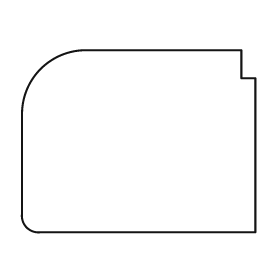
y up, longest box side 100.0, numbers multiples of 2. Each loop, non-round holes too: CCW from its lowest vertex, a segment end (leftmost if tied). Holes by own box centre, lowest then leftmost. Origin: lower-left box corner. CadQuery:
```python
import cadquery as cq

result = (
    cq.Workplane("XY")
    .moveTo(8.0, 0.0)
    .lineTo(100.0, 0.0)
    .lineTo(100.0, 66.0)
    .lineTo(94.0, 66.0)
    .lineTo(94.0, 78.0)
    .lineTo(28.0, 78.0)
    .threePointArc((8.0, 70.0), (0.0, 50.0))
    .lineTo(0.0, 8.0)
    .threePointArc((2.0, 2.0), (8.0, 0.0))
    .close()
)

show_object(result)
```